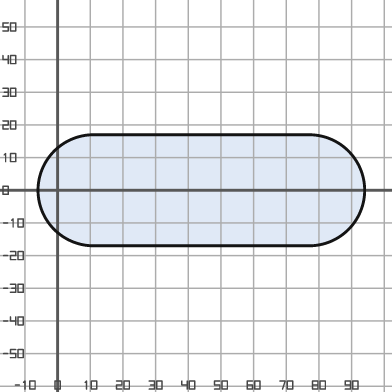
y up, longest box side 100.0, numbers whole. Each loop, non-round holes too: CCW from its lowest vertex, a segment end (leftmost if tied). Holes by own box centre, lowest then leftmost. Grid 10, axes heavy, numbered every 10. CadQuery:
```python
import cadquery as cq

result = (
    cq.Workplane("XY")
    .moveTo(11.0, -17.0)
    .lineTo(77.0, -17.0)
    .threePointArc((94.0, 0.0), (77.0, 17.0))
    .lineTo(11.0, 17.0)
    .threePointArc((-6.0, 0.0), (11.0, -17.0))
    .close()
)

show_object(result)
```